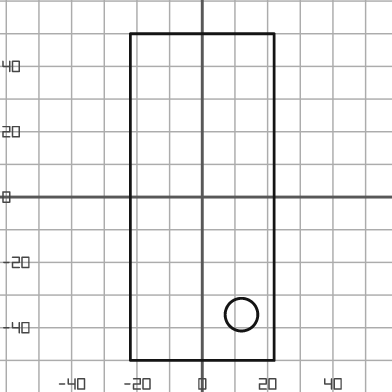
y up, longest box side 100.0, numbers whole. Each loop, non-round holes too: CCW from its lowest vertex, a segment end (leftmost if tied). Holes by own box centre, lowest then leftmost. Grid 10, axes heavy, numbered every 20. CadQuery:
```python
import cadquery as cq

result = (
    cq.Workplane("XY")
    .moveTo(-22.0, -50.0)
    .lineTo(22.0, -50.0)
    .lineTo(22.0, 50.0)
    .lineTo(-22.0, 50.0)
    .close()
    .moveTo(12.0, -36.0)
    .circle(5.0)
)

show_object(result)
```